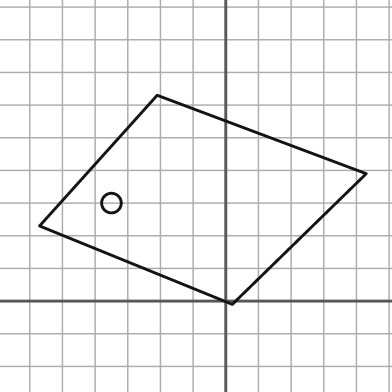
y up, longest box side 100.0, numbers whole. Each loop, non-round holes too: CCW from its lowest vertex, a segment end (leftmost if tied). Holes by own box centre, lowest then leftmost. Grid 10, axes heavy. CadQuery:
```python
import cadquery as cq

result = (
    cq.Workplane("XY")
    .moveTo(2.0, -1.0)
    .lineTo(43.0, 39.0)
    .lineTo(-21.0, 63.0)
    .lineTo(-57.0, 23.0)
    .close()
    .moveTo(-35.0, 30.0)
    .circle(3.0)
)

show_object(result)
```